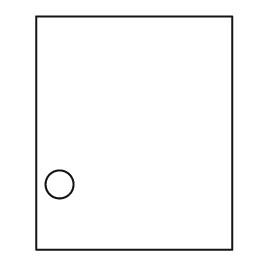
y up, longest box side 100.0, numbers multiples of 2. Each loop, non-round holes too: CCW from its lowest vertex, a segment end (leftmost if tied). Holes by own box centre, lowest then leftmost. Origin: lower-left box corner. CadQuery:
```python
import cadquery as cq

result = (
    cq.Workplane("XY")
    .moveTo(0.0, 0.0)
    .lineTo(84.0, 0.0)
    .lineTo(84.0, 100.0)
    .lineTo(0.0, 100.0)
    .close()
    .moveTo(10.0, 28.0)
    .circle(6.0)
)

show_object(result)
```